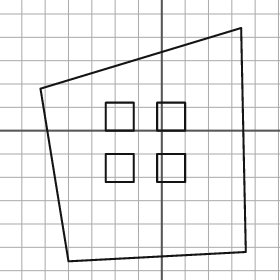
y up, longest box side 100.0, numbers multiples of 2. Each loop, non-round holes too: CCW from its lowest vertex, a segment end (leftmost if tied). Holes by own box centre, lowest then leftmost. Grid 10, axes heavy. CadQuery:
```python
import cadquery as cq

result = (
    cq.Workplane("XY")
    .moveTo(-40.0, -56.0)
    .lineTo(36.0, -52.0)
    .lineTo(34.0, 44.0)
    .lineTo(-52.0, 18.0)
    .close()
    .moveTo(-24.0, -22.0)
    .lineTo(-12.0, -22.0)
    .lineTo(-12.0, -10.0)
    .lineTo(-24.0, -10.0)
    .close()
    .moveTo(-2.0, -22.0)
    .lineTo(10.0, -22.0)
    .lineTo(10.0, -10.0)
    .lineTo(-2.0, -10.0)
    .close()
    .moveTo(-24.0, 0.0)
    .lineTo(-12.0, 0.0)
    .lineTo(-12.0, 12.0)
    .lineTo(-24.0, 12.0)
    .close()
    .moveTo(-2.0, 0.0)
    .lineTo(10.0, 0.0)
    .lineTo(10.0, 12.0)
    .lineTo(-2.0, 12.0)
    .close()
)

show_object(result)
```